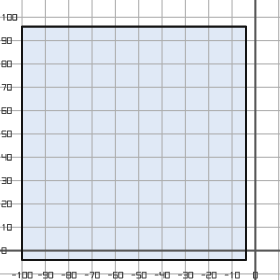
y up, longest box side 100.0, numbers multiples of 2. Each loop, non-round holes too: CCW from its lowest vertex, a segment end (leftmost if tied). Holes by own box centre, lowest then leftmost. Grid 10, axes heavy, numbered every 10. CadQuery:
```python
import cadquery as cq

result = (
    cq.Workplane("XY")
    .moveTo(-100.0, -4.0)
    .lineTo(-4.0, -4.0)
    .lineTo(-4.0, 96.0)
    .lineTo(-100.0, 96.0)
    .close()
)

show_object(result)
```